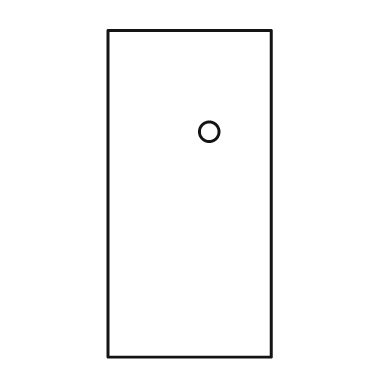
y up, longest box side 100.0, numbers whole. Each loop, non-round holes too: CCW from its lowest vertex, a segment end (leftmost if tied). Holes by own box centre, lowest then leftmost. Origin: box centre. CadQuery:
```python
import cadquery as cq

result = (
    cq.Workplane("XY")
    .moveTo(-25.0, -50.0)
    .lineTo(25.0, -50.0)
    .lineTo(25.0, 50.0)
    .lineTo(-25.0, 50.0)
    .close()
    .moveTo(6.0, 19.0)
    .circle(3.0)
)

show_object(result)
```